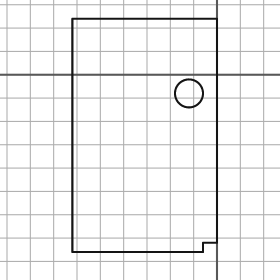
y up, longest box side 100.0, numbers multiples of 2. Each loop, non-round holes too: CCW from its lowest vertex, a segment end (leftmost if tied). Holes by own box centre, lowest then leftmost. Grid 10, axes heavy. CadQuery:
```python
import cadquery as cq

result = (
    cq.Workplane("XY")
    .moveTo(-62.0, -76.0)
    .lineTo(-6.0, -76.0)
    .lineTo(-6.0, -72.0)
    .lineTo(0.0, -72.0)
    .lineTo(0.0, 24.0)
    .lineTo(-62.0, 24.0)
    .close()
    .moveTo(-12.0, -8.0)
    .circle(6.0)
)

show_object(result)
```